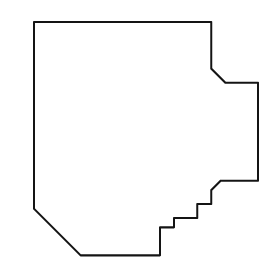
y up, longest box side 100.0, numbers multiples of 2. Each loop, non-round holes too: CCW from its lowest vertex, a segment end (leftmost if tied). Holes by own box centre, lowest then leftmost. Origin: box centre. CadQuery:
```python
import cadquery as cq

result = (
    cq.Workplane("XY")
    .moveTo(-28.0, -50.0)
    .lineTo(6.0, -50.0)
    .lineTo(6.0, -38.0)
    .lineTo(12.0, -38.0)
    .lineTo(12.0, -34.0)
    .lineTo(22.0, -34.0)
    .lineTo(22.0, -28.0)
    .lineTo(28.0, -28.0)
    .lineTo(28.0, -22.0)
    .lineTo(32.0, -18.0)
    .lineTo(48.0, -18.0)
    .lineTo(48.0, 24.0)
    .lineTo(34.0, 24.0)
    .lineTo(28.0, 30.0)
    .lineTo(28.0, 50.0)
    .lineTo(-48.0, 50.0)
    .lineTo(-48.0, -30.0)
    .close()
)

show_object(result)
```